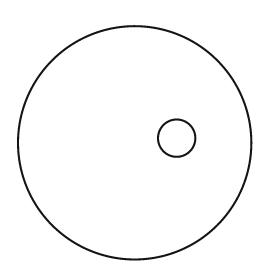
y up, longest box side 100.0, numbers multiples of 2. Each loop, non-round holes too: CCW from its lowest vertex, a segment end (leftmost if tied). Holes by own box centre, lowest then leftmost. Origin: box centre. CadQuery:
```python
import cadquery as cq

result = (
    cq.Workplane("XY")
    .moveTo(0.0, 0.0)
    .circle(50.0)
    .moveTo(18.0, 2.0)
    .circle(8.0)
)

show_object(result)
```